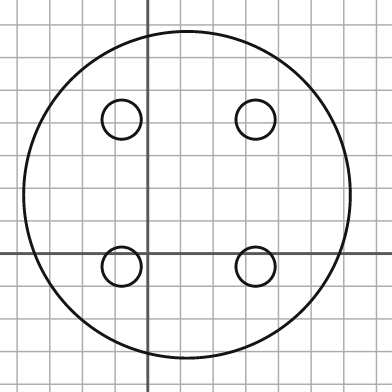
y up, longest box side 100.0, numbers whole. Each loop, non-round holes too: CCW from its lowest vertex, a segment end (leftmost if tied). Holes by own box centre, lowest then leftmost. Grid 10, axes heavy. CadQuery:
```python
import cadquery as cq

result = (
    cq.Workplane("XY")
    .moveTo(12.0, 18.0)
    .circle(50.0)
    .moveTo(-8.0, -4.0)
    .circle(6.0)
    .moveTo(33.0, -4.0)
    .circle(6.0)
    .moveTo(-8.0, 41.0)
    .circle(6.0)
    .moveTo(33.0, 41.0)
    .circle(6.0)
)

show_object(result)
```